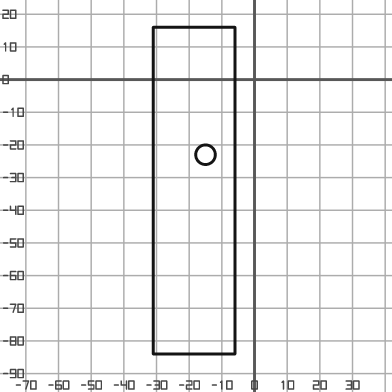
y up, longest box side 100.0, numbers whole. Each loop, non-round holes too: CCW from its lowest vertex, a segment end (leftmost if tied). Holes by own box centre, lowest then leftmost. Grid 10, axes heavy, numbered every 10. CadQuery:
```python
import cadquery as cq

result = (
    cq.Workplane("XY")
    .moveTo(-31.0, -84.0)
    .lineTo(-6.0, -84.0)
    .lineTo(-6.0, 16.0)
    .lineTo(-31.0, 16.0)
    .close()
    .moveTo(-15.0, -23.0)
    .circle(3.0)
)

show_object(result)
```